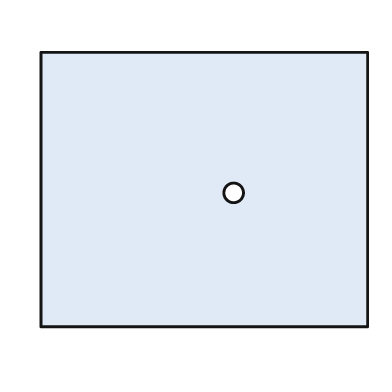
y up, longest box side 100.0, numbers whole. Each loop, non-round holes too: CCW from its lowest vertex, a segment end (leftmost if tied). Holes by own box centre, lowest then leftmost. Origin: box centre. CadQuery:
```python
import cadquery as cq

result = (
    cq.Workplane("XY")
    .moveTo(-50.0, -42.0)
    .lineTo(50.0, -42.0)
    .lineTo(50.0, 42.0)
    .lineTo(-50.0, 42.0)
    .close()
    .moveTo(9.0, -1.0)
    .circle(3.0)
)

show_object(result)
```